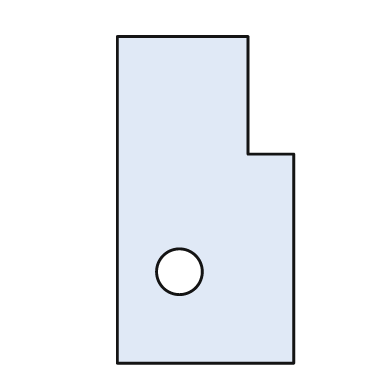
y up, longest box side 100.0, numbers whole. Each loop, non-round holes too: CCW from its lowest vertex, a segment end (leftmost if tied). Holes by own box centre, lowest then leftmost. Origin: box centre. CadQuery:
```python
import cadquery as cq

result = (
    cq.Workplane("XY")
    .moveTo(-27.0, -50.0)
    .lineTo(27.0, -50.0)
    .lineTo(27.0, 14.0)
    .lineTo(13.0, 14.0)
    .lineTo(13.0, 50.0)
    .lineTo(-27.0, 50.0)
    .close()
    .moveTo(-8.0, -22.0)
    .circle(7.0)
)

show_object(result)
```